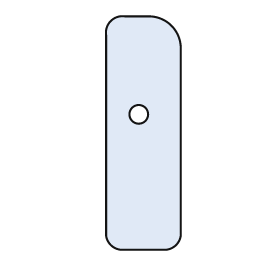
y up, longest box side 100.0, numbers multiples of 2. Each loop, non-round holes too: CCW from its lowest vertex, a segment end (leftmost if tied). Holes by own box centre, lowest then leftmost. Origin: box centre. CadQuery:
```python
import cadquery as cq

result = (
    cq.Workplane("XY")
    .moveTo(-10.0, -50.0)
    .lineTo(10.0, -50.0)
    .threePointArc((14.0, -48.0), (16.0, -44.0))
    .lineTo(16.0, 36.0)
    .threePointArc((12.0, 46.0), (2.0, 50.0))
    .lineTo(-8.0, 50.0)
    .threePointArc((-14.0, 48.0), (-16.0, 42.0))
    .lineTo(-16.0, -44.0)
    .threePointArc((-14.0, -48.0), (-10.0, -50.0))
    .close()
    .moveTo(-2.0, 8.0)
    .circle(4.0)
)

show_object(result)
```